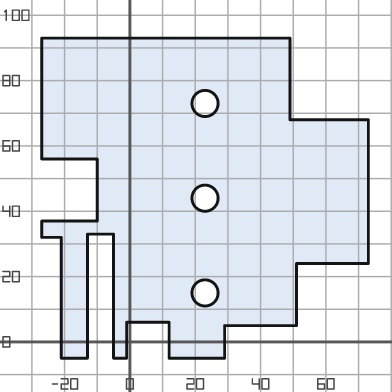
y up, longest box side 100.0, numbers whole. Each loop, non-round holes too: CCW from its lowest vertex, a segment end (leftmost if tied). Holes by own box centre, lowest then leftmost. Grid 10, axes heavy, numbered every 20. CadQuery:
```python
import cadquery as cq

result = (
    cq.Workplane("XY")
    .moveTo(-21.0, -5.0)
    .lineTo(-13.0, -5.0)
    .lineTo(-13.0, 33.0)
    .lineTo(-5.0, 33.0)
    .lineTo(-5.0, -5.0)
    .lineTo(-1.0, -5.0)
    .lineTo(-1.0, 6.0)
    .lineTo(12.0, 6.0)
    .lineTo(12.0, -5.0)
    .lineTo(29.0, -5.0)
    .lineTo(29.0, 5.0)
    .lineTo(51.0, 5.0)
    .lineTo(51.0, 24.0)
    .lineTo(73.0, 24.0)
    .lineTo(73.0, 68.0)
    .lineTo(49.0, 68.0)
    .lineTo(49.0, 93.0)
    .lineTo(-27.0, 93.0)
    .lineTo(-27.0, 56.0)
    .lineTo(-10.0, 56.0)
    .lineTo(-10.0, 37.0)
    .lineTo(-27.0, 37.0)
    .lineTo(-27.0, 32.0)
    .lineTo(-21.0, 32.0)
    .close()
    .moveTo(23.0, 15.0)
    .circle(4.0)
    .moveTo(23.0, 44.0)
    .circle(4.0)
    .moveTo(23.0, 73.0)
    .circle(4.0)
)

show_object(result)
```